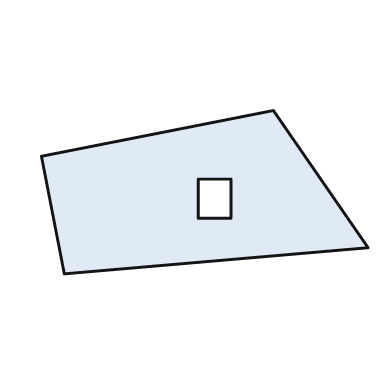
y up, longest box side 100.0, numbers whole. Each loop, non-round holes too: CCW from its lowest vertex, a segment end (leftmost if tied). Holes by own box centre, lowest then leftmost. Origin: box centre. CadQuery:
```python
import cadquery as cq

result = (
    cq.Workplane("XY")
    .moveTo(-43.0, -25.0)
    .lineTo(50.0, -17.0)
    .lineTo(21.0, 25.0)
    .lineTo(-50.0, 11.0)
    .close()
    .moveTo(-2.0, -8.0)
    .lineTo(8.0, -8.0)
    .lineTo(8.0, 4.0)
    .lineTo(-2.0, 4.0)
    .close()
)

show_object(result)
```